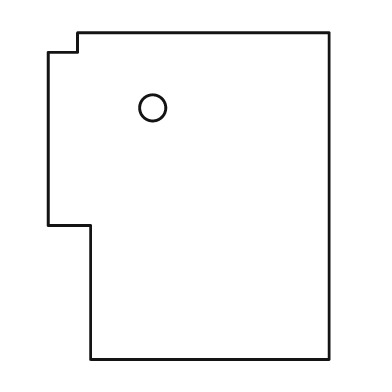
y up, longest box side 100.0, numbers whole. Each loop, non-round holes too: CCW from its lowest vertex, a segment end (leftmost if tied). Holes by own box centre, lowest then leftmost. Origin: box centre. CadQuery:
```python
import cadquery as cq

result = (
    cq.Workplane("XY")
    .moveTo(-30.0, -50.0)
    .lineTo(43.0, -50.0)
    .lineTo(43.0, 50.0)
    .lineTo(-34.0, 50.0)
    .lineTo(-34.0, 44.0)
    .lineTo(-43.0, 44.0)
    .lineTo(-43.0, -9.0)
    .lineTo(-30.0, -9.0)
    .close()
    .moveTo(-11.0, 27.0)
    .circle(4.0)
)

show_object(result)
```